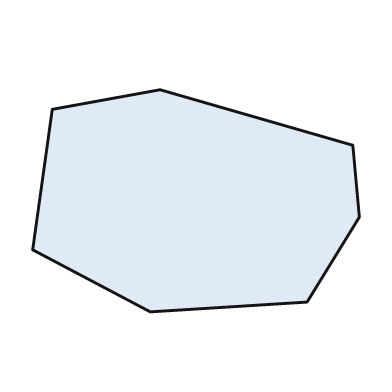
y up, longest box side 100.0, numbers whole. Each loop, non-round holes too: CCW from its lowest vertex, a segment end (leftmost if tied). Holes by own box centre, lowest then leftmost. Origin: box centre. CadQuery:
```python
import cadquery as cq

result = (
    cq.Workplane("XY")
    .moveTo(-14.0, -34.0)
    .lineTo(34.0, -31.0)
    .lineTo(50.0, -5.0)
    .lineTo(48.0, 17.0)
    .lineTo(-11.0, 34.0)
    .lineTo(-44.0, 28.0)
    .lineTo(-50.0, -15.0)
    .close()
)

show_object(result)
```